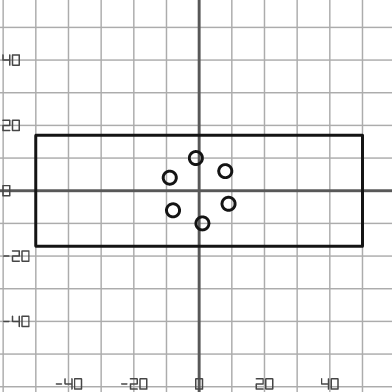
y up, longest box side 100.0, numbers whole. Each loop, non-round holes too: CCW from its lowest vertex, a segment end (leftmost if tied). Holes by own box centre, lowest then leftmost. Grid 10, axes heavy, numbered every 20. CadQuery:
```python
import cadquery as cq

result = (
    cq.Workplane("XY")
    .moveTo(-50.0, -17.0)
    .lineTo(50.0, -17.0)
    .lineTo(50.0, 17.0)
    .lineTo(-50.0, 17.0)
    .close()
    .moveTo(1.0, -10.0)
    .circle(2.0)
    .moveTo(-8.0, -6.0)
    .circle(2.0)
    .moveTo(9.0, -4.0)
    .circle(2.0)
    .moveTo(-9.0, 4.0)
    .circle(2.0)
    .moveTo(8.0, 6.0)
    .circle(2.0)
    .moveTo(-1.0, 10.0)
    .circle(2.0)
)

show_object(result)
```